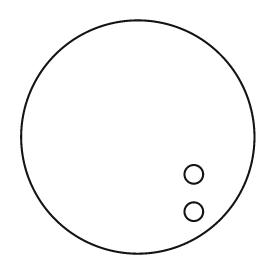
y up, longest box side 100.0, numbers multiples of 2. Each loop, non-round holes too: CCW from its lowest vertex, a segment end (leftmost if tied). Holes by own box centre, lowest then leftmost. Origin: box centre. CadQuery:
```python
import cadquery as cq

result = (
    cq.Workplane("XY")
    .moveTo(0.0, 0.0)
    .circle(50.0)
    .moveTo(24.0, -32.0)
    .circle(4.0)
    .moveTo(24.0, -16.0)
    .circle(4.0)
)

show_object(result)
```